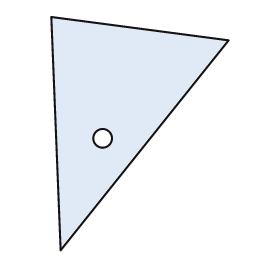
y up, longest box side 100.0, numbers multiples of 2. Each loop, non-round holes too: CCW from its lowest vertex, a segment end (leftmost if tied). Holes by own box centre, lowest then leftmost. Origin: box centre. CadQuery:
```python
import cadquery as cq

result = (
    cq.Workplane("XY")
    .moveTo(-34.0, -50.0)
    .lineTo(38.0, 40.0)
    .lineTo(-38.0, 50.0)
    .close()
    .moveTo(-16.0, -2.0)
    .circle(4.0)
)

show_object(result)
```